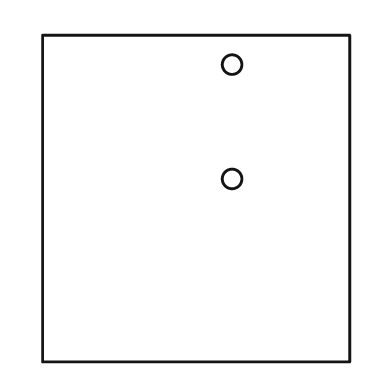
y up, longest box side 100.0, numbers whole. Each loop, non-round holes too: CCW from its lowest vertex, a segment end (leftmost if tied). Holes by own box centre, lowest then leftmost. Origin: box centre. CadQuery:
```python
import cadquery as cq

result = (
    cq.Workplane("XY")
    .moveTo(-47.0, -50.0)
    .lineTo(47.0, -50.0)
    .lineTo(47.0, 50.0)
    .lineTo(-47.0, 50.0)
    .close()
    .moveTo(11.0, 6.0)
    .circle(3.0)
    .moveTo(11.0, 41.0)
    .circle(3.0)
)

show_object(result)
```